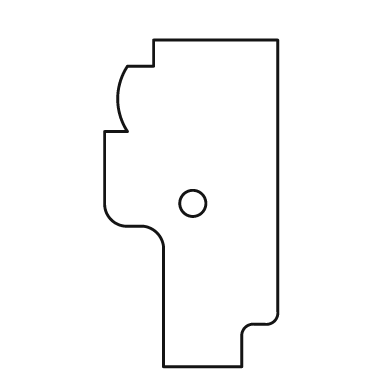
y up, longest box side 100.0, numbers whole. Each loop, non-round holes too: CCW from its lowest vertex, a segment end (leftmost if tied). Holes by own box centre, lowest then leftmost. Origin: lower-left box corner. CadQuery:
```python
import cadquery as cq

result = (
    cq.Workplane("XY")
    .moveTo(18.0, 0.0)
    .lineTo(42.0, 0.0)
    .lineTo(42.0, 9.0)
    .threePointArc((43.0, 12.0), (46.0, 13.0))
    .lineTo(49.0, 13.0)
    .threePointArc((52.0, 14.0), (53.0, 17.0))
    .lineTo(53.0, 100.0)
    .lineTo(15.0, 100.0)
    .lineTo(15.0, 92.0)
    .lineTo(7.0, 92.0)
    .threePointArc((4.0, 82.0), (7.0, 72.0))
    .lineTo(0.0, 72.0)
    .lineTo(0.0, 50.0)
    .threePointArc((2.0, 45.0), (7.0, 43.0))
    .lineTo(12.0, 43.0)
    .threePointArc((16.0, 41.0), (18.0, 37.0))
    .close()
    .moveTo(27.0, 50.0)
    .circle(4.0)
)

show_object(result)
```